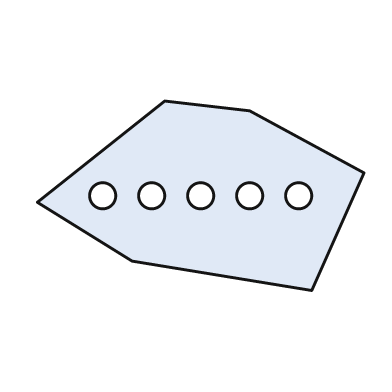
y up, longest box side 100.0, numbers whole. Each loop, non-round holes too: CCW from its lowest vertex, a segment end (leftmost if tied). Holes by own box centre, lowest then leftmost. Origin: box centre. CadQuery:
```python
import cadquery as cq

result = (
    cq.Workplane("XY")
    .moveTo(34.0, -29.0)
    .lineTo(50.0, 7.0)
    .lineTo(15.0, 26.0)
    .lineTo(-11.0, 29.0)
    .lineTo(-50.0, -2.0)
    .lineTo(-21.0, -20.0)
    .close()
    .moveTo(-30.0, 0.0)
    .circle(4.0)
    .moveTo(-15.0, 0.0)
    .circle(4.0)
    .moveTo(0.0, 0.0)
    .circle(4.0)
    .moveTo(15.0, 0.0)
    .circle(4.0)
    .moveTo(30.0, 0.0)
    .circle(4.0)
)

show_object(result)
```